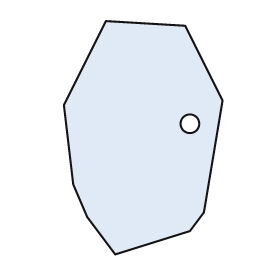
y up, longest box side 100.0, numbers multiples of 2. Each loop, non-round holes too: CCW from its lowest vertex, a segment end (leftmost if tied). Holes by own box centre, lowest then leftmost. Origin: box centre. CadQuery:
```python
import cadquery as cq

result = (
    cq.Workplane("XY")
    .moveTo(-12.0, -50.0)
    .lineTo(20.0, -40.0)
    .lineTo(26.0, -32.0)
    .lineTo(34.0, 16.0)
    .lineTo(18.0, 48.0)
    .lineTo(-16.0, 50.0)
    .lineTo(-34.0, 14.0)
    .lineTo(-30.0, -20.0)
    .lineTo(-24.0, -34.0)
    .close()
    .moveTo(20.0, 6.0)
    .circle(4.0)
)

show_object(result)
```